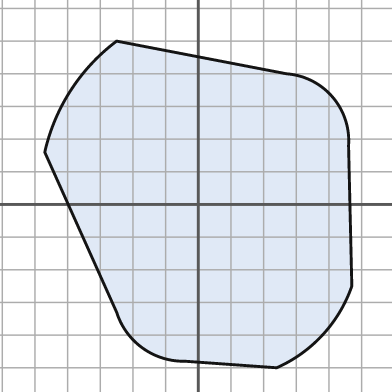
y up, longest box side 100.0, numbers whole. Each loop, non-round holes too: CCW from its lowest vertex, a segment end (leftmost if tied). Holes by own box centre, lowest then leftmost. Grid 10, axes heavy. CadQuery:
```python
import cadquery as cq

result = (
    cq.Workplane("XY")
    .moveTo(24.0, -50.0)
    .threePointArc((38.0, -40.0), (47.0, -25.0))
    .lineTo(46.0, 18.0)
    .threePointArc((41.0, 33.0), (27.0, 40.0))
    .lineTo(-25.0, 50.0)
    .threePointArc((-39.0, 35.0), (-47.0, 16.0))
    .lineTo(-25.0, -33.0)
    .threePointArc((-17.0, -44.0), (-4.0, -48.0))
    .close()
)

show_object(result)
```